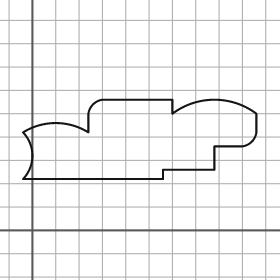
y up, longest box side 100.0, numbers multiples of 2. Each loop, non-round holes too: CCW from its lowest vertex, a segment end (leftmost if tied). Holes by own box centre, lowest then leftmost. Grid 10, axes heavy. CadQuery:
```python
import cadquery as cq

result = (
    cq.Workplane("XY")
    .moveTo(-4.0, 22.0)
    .lineTo(56.0, 22.0)
    .lineTo(56.0, 26.0)
    .lineTo(78.0, 26.0)
    .lineTo(78.0, 36.0)
    .lineTo(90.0, 36.0)
    .threePointArc((94.0, 38.0), (96.0, 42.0))
    .lineTo(96.0, 50.0)
    .threePointArc((78.0, 56.0), (60.0, 50.0))
    .lineTo(60.0, 56.0)
    .lineTo(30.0, 56.0)
    .threePointArc((26.0, 54.0), (24.0, 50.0))
    .lineTo(24.0, 42.0)
    .threePointArc((10.0, 46.0), (-4.0, 42.0))
    .threePointArc((0.0, 32.0), (-4.0, 22.0))
    .close()
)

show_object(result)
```